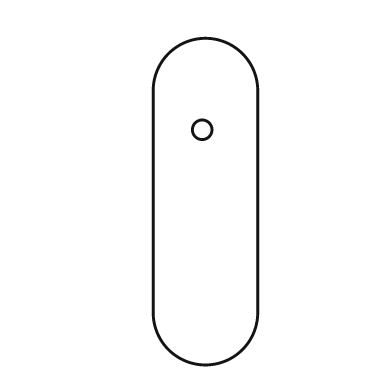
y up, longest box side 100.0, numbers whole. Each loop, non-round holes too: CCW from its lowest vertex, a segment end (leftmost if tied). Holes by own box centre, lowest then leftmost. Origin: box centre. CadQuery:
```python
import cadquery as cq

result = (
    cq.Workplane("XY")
    .moveTo(-16.0, -34.0)
    .threePointArc((0.0, -50.0), (16.0, -34.0))
    .lineTo(16.0, 34.0)
    .threePointArc((0.0, 50.0), (-16.0, 34.0))
    .close()
    .moveTo(-1.0, 22.0)
    .circle(3.0)
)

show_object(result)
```